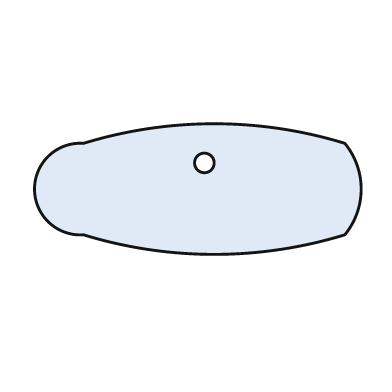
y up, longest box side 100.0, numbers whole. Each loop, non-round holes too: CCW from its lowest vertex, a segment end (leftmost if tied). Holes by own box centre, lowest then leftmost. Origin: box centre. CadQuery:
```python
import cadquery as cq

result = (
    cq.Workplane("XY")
    .moveTo(-35.0, -14.0)
    .threePointArc((5.0, -20.0), (45.0, -14.0))
    .threePointArc((50.0, 0.0), (45.0, 14.0))
    .threePointArc((5.0, 20.0), (-35.0, 14.0))
    .threePointArc((-50.0, 0.0), (-35.0, -14.0))
    .close()
    .moveTo(2.0, 8.0)
    .circle(3.0)
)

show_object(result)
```